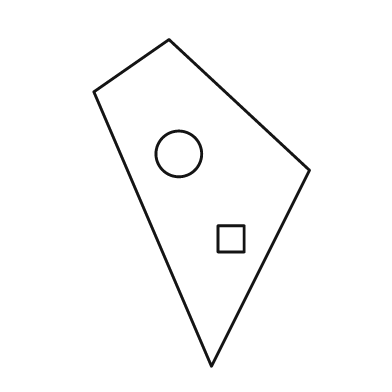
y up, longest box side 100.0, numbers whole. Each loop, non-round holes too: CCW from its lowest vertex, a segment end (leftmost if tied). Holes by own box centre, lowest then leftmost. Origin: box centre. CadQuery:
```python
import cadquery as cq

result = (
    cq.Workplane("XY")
    .moveTo(3.0, -50.0)
    .lineTo(33.0, 10.0)
    .lineTo(-10.0, 50.0)
    .lineTo(-33.0, 34.0)
    .close()
    .moveTo(5.0, -15.0)
    .lineTo(13.0, -15.0)
    .lineTo(13.0, -7.0)
    .lineTo(5.0, -7.0)
    .close()
    .moveTo(-7.0, 15.0)
    .circle(7.0)
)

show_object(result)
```